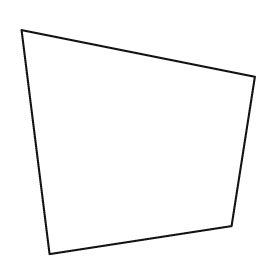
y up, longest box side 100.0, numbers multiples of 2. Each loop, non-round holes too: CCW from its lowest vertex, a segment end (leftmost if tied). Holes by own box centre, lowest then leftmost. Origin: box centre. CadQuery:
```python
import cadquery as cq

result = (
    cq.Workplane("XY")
    .moveTo(-38.0, -48.0)
    .lineTo(40.0, -36.0)
    .lineTo(50.0, 28.0)
    .lineTo(-50.0, 48.0)
    .close()
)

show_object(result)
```